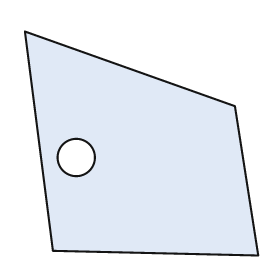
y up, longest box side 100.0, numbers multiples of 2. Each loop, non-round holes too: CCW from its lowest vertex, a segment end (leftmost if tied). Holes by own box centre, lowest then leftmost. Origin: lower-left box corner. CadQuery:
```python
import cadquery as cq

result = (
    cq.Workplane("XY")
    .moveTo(100.0, 0.0)
    .lineTo(90.0, 64.0)
    .lineTo(0.0, 96.0)
    .lineTo(12.0, 2.0)
    .close()
    .moveTo(22.0, 42.0)
    .circle(8.0)
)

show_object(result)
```